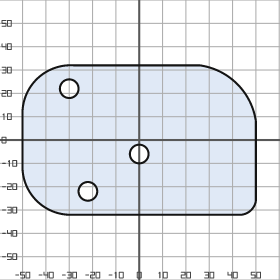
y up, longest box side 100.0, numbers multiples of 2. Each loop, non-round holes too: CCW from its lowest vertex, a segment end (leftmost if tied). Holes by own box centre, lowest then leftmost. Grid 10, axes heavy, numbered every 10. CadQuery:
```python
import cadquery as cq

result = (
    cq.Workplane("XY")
    .moveTo(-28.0, -32.0)
    .lineTo(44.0, -32.0)
    .threePointArc((48.0, -30.0), (50.0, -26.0))
    .lineTo(50.0, 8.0)
    .threePointArc((42.0, 24.0), (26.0, 32.0))
    .lineTo(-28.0, 32.0)
    .threePointArc((-44.0, 26.0), (-50.0, 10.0))
    .lineTo(-50.0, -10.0)
    .threePointArc((-44.0, -26.0), (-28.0, -32.0))
    .close()
    .moveTo(-22.0, -22.0)
    .circle(4.0)
    .moveTo(0.0, -6.0)
    .circle(4.0)
    .moveTo(-30.0, 22.0)
    .circle(4.0)
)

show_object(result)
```